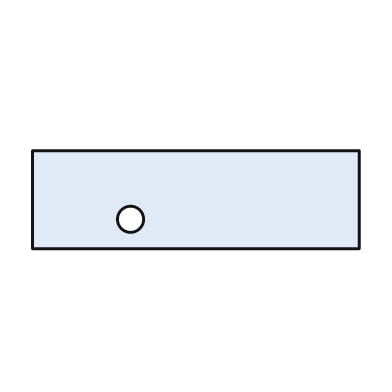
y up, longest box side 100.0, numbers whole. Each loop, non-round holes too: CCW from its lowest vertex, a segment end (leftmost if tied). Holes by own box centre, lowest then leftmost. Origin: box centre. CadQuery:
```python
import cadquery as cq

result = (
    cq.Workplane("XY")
    .moveTo(-50.0, -15.0)
    .lineTo(50.0, -15.0)
    .lineTo(50.0, 15.0)
    .lineTo(-50.0, 15.0)
    .close()
    .moveTo(-20.0, -6.0)
    .circle(4.0)
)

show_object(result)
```